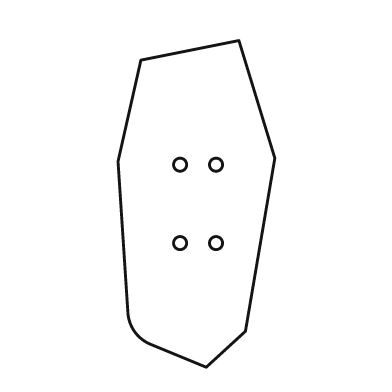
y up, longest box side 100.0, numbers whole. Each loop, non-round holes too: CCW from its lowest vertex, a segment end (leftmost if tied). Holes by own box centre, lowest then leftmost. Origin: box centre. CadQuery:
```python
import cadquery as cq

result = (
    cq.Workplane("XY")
    .moveTo(3.0, -50.0)
    .lineTo(15.0, -39.0)
    .lineTo(24.0, 14.0)
    .lineTo(13.0, 50.0)
    .lineTo(-17.0, 44.0)
    .lineTo(-24.0, 13.0)
    .lineTo(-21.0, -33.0)
    .threePointArc((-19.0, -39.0), (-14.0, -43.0))
    .close()
    .moveTo(-5.0, -12.0)
    .circle(2.0)
    .moveTo(6.0, -12.0)
    .circle(2.0)
    .moveTo(-5.0, 12.0)
    .circle(2.0)
    .moveTo(6.0, 12.0)
    .circle(2.0)
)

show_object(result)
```